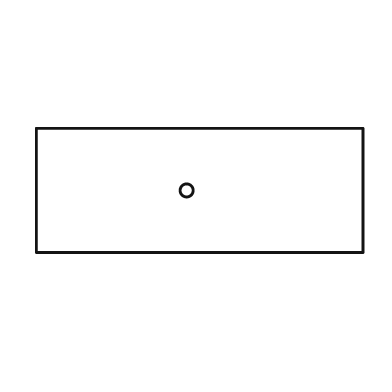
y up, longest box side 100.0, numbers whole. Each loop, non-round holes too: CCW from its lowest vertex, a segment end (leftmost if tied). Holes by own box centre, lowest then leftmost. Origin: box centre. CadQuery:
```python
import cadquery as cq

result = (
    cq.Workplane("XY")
    .moveTo(-50.0, -19.0)
    .lineTo(50.0, -19.0)
    .lineTo(50.0, 19.0)
    .lineTo(-50.0, 19.0)
    .close()
    .moveTo(-4.0, 0.0)
    .circle(2.0)
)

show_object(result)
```